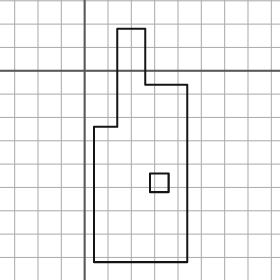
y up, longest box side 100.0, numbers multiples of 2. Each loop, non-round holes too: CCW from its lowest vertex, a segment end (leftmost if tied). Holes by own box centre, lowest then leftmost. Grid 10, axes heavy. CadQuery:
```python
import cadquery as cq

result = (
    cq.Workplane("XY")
    .moveTo(4.0, -82.0)
    .lineTo(44.0, -82.0)
    .lineTo(44.0, -6.0)
    .lineTo(26.0, -6.0)
    .lineTo(26.0, 18.0)
    .lineTo(14.0, 18.0)
    .lineTo(14.0, -24.0)
    .lineTo(4.0, -24.0)
    .close()
    .moveTo(28.0, -52.0)
    .lineTo(36.0, -52.0)
    .lineTo(36.0, -44.0)
    .lineTo(28.0, -44.0)
    .close()
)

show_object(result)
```